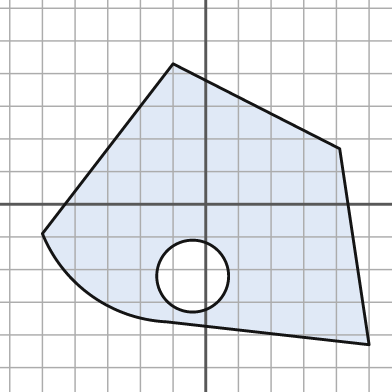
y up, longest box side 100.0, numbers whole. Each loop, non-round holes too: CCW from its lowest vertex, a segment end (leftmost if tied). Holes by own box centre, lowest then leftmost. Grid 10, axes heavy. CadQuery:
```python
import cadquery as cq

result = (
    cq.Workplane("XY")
    .moveTo(50.0, -43.0)
    .lineTo(41.0, 17.0)
    .lineTo(-10.0, 43.0)
    .lineTo(-50.0, -9.0)
    .threePointArc((-35.0, -28.0), (-12.0, -36.0))
    .close()
    .moveTo(-4.0, -22.0)
    .circle(11.0)
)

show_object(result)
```